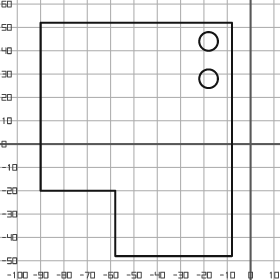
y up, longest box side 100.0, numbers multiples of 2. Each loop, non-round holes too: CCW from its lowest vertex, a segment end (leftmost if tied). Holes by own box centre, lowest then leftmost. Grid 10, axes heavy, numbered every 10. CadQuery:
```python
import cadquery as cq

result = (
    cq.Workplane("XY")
    .moveTo(-58.0, -48.0)
    .lineTo(-8.0, -48.0)
    .lineTo(-8.0, 52.0)
    .lineTo(-90.0, 52.0)
    .lineTo(-90.0, -20.0)
    .lineTo(-58.0, -20.0)
    .close()
    .moveTo(-18.0, 28.0)
    .circle(4.0)
    .moveTo(-18.0, 44.0)
    .circle(4.0)
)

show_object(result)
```